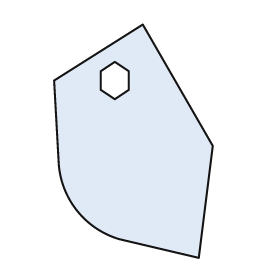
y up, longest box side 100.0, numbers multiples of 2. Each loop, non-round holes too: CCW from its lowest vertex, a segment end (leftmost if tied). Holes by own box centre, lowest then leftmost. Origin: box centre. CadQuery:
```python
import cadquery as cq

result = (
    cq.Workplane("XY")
    .moveTo(28.0, -50.0)
    .lineTo(34.0, -2.0)
    .lineTo(4.0, 50.0)
    .lineTo(-34.0, 26.0)
    .lineTo(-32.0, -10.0)
    .threePointArc((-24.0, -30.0), (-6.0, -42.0))
    .close()
    .moveTo(-8.0, 18.0)
    .lineTo(-2.0, 22.0)
    .lineTo(-2.0, 30.0)
    .lineTo(-8.0, 34.0)
    .lineTo(-14.0, 30.0)
    .lineTo(-14.0, 22.0)
    .close()
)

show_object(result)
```